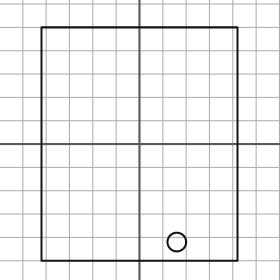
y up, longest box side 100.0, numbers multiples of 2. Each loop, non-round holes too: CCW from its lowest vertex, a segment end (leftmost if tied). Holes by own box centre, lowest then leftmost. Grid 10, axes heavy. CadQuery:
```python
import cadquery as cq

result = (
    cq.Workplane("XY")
    .moveTo(-42.0, -50.0)
    .lineTo(42.0, -50.0)
    .lineTo(42.0, 50.0)
    .lineTo(-42.0, 50.0)
    .close()
    .moveTo(16.0, -42.0)
    .circle(4.0)
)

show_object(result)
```